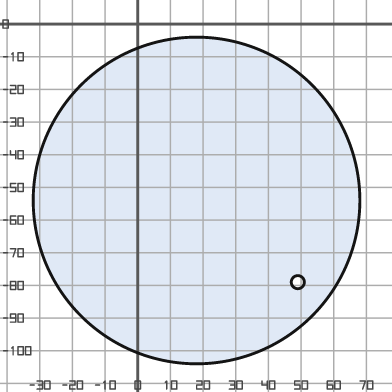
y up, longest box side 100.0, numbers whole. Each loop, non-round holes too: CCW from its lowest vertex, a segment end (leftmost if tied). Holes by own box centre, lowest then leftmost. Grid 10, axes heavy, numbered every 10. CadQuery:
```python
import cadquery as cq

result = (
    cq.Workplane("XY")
    .moveTo(18.0, -54.0)
    .circle(50.0)
    .moveTo(49.0, -79.0)
    .circle(2.0)
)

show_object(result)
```